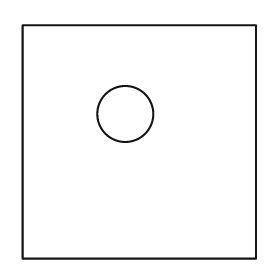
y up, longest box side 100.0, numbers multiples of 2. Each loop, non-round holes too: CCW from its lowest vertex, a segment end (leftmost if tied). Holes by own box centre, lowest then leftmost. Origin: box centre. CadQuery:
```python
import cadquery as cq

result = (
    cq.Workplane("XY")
    .moveTo(-50.0, -50.0)
    .lineTo(50.0, -50.0)
    .lineTo(50.0, 50.0)
    .lineTo(-50.0, 50.0)
    .close()
    .moveTo(-6.0, 12.0)
    .circle(12.0)
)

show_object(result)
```